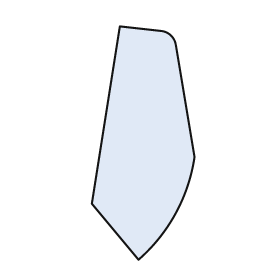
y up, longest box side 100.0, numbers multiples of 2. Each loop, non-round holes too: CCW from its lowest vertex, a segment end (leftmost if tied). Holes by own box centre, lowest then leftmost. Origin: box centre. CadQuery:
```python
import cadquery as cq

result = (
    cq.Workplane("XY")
    .moveTo(-2.0, -50.0)
    .threePointArc((14.0, -30.0), (22.0, -6.0))
    .lineTo(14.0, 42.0)
    .threePointArc((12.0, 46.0), (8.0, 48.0))
    .lineTo(-10.0, 50.0)
    .lineTo(-22.0, -26.0)
    .close()
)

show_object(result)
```